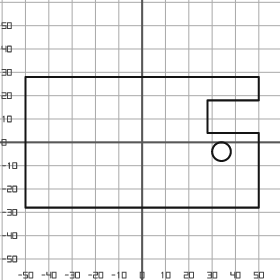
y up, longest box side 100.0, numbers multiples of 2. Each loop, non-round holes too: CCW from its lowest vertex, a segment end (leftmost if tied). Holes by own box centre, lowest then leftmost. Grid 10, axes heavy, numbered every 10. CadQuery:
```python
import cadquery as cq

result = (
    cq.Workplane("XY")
    .moveTo(-50.0, -28.0)
    .lineTo(50.0, -28.0)
    .lineTo(50.0, 4.0)
    .lineTo(28.0, 4.0)
    .lineTo(28.0, 18.0)
    .lineTo(50.0, 18.0)
    .lineTo(50.0, 28.0)
    .lineTo(-50.0, 28.0)
    .close()
    .moveTo(34.0, -4.0)
    .circle(4.0)
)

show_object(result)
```